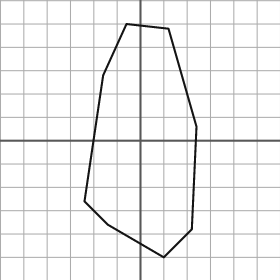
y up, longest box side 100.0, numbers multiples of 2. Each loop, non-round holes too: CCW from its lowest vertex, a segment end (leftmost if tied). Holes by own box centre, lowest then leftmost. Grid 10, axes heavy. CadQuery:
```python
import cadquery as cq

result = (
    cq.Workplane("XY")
    .moveTo(10.0, -50.0)
    .lineTo(22.0, -38.0)
    .lineTo(24.0, 6.0)
    .lineTo(12.0, 48.0)
    .lineTo(-6.0, 50.0)
    .lineTo(-16.0, 28.0)
    .lineTo(-24.0, -26.0)
    .lineTo(-14.0, -36.0)
    .close()
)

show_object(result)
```